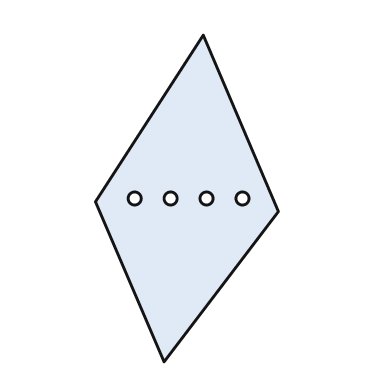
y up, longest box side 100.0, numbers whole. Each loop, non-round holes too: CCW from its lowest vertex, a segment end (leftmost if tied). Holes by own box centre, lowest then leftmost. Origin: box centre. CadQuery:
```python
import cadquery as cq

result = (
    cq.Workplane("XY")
    .moveTo(-7.0, -50.0)
    .lineTo(28.0, -4.0)
    .lineTo(5.0, 50.0)
    .lineTo(-28.0, -1.0)
    .close()
    .moveTo(-16.0, 0.0)
    .circle(2.0)
    .moveTo(-5.0, 0.0)
    .circle(2.0)
    .moveTo(6.0, 0.0)
    .circle(2.0)
    .moveTo(17.0, 0.0)
    .circle(2.0)
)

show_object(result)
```